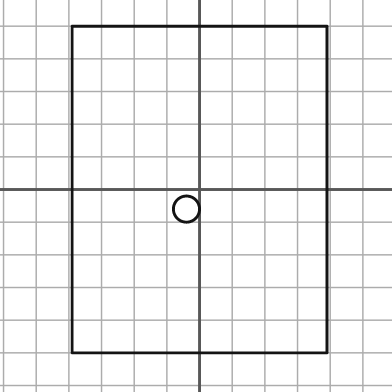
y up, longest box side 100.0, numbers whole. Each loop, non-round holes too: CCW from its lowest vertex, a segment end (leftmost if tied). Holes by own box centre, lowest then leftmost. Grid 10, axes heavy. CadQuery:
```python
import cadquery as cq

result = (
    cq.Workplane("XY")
    .moveTo(-39.0, -50.0)
    .lineTo(39.0, -50.0)
    .lineTo(39.0, 50.0)
    .lineTo(-39.0, 50.0)
    .close()
    .moveTo(-4.0, -6.0)
    .circle(4.0)
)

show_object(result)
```